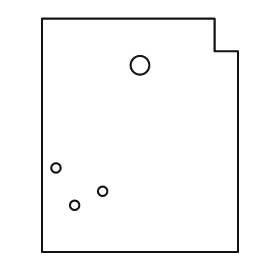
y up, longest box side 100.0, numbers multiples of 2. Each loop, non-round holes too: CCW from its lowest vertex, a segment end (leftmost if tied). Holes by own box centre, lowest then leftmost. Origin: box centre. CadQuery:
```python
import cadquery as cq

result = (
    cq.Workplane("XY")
    .moveTo(-42.0, -50.0)
    .lineTo(42.0, -50.0)
    .lineTo(42.0, 36.0)
    .lineTo(32.0, 36.0)
    .lineTo(32.0, 50.0)
    .lineTo(-42.0, 50.0)
    .close()
    .moveTo(-28.0, -30.0)
    .circle(2.0)
    .moveTo(-16.0, -24.0)
    .circle(2.0)
    .moveTo(-36.0, -14.0)
    .circle(2.0)
    .moveTo(0.0, 30.0)
    .circle(4.0)
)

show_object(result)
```